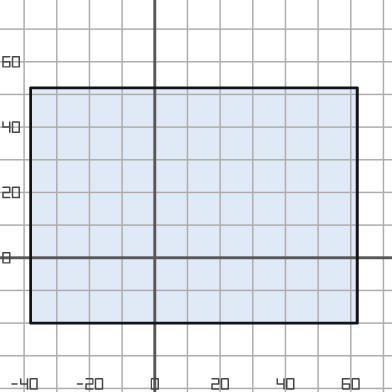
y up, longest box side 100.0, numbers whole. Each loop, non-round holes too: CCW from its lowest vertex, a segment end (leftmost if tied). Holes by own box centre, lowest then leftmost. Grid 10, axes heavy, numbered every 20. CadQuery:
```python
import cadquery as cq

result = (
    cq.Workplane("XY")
    .moveTo(-38.0, -20.0)
    .lineTo(62.0, -20.0)
    .lineTo(62.0, 52.0)
    .lineTo(-38.0, 52.0)
    .close()
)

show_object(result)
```